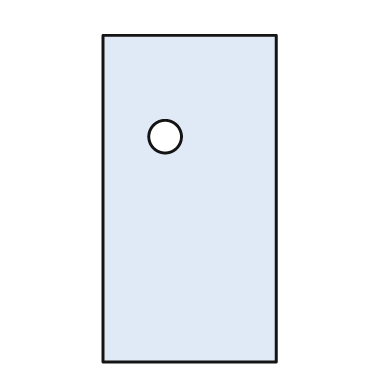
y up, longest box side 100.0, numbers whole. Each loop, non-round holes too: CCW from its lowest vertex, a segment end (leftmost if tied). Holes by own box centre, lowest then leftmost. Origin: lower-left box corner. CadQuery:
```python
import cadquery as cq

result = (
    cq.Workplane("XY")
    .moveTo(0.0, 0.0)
    .lineTo(53.0, 0.0)
    .lineTo(53.0, 100.0)
    .lineTo(0.0, 100.0)
    .close()
    .moveTo(19.0, 69.0)
    .circle(5.0)
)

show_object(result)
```